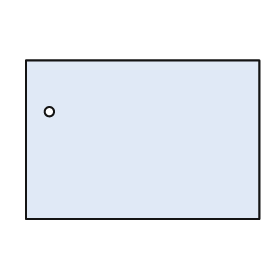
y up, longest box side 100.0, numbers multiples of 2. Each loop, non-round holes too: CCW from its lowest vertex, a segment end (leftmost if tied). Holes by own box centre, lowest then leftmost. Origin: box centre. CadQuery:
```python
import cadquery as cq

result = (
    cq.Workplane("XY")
    .moveTo(-50.0, -34.0)
    .lineTo(50.0, -34.0)
    .lineTo(50.0, 34.0)
    .lineTo(-50.0, 34.0)
    .close()
    .moveTo(-40.0, 12.0)
    .circle(2.0)
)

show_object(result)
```